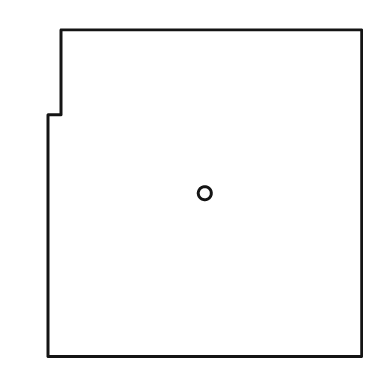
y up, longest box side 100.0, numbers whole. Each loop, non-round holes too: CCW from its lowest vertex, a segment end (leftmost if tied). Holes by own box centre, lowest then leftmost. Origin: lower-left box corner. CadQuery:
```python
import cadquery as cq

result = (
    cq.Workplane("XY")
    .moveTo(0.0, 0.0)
    .lineTo(96.0, 0.0)
    .lineTo(96.0, 100.0)
    .lineTo(4.0, 100.0)
    .lineTo(4.0, 74.0)
    .lineTo(0.0, 74.0)
    .close()
    .moveTo(48.0, 50.0)
    .circle(2.0)
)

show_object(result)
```